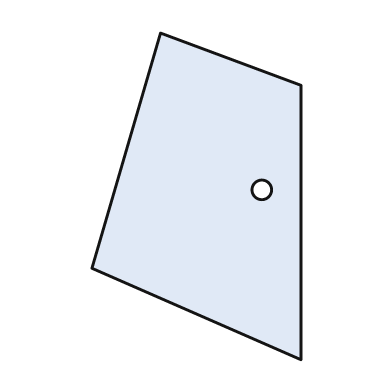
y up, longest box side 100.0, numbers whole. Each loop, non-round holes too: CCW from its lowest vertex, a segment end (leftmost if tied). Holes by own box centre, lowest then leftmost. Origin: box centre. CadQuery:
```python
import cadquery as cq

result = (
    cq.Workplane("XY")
    .moveTo(32.0, -50.0)
    .lineTo(32.0, 34.0)
    .lineTo(-11.0, 50.0)
    .lineTo(-32.0, -22.0)
    .close()
    .moveTo(20.0, 2.0)
    .circle(3.0)
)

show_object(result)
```